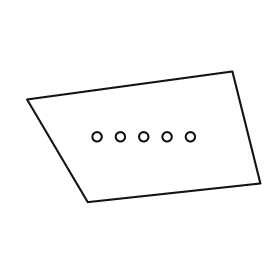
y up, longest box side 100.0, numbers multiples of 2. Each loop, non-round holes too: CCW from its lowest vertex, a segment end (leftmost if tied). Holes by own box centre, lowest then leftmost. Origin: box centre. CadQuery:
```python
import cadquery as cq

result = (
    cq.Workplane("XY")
    .moveTo(-24.0, -28.0)
    .lineTo(50.0, -20.0)
    .lineTo(38.0, 28.0)
    .lineTo(-50.0, 16.0)
    .close()
    .moveTo(-20.0, 0.0)
    .circle(2.0)
    .moveTo(-10.0, 0.0)
    .circle(2.0)
    .moveTo(0.0, 0.0)
    .circle(2.0)
    .moveTo(10.0, 0.0)
    .circle(2.0)
    .moveTo(20.0, 0.0)
    .circle(2.0)
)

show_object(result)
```